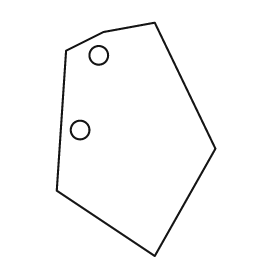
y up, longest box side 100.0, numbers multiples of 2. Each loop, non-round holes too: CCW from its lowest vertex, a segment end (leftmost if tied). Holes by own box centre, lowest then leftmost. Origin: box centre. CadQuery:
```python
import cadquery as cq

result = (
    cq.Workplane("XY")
    .moveTo(8.0, -50.0)
    .lineTo(34.0, -4.0)
    .lineTo(8.0, 50.0)
    .lineTo(-14.0, 46.0)
    .lineTo(-30.0, 38.0)
    .lineTo(-34.0, -22.0)
    .close()
    .moveTo(-24.0, 4.0)
    .circle(4.0)
    .moveTo(-16.0, 36.0)
    .circle(4.0)
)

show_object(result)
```